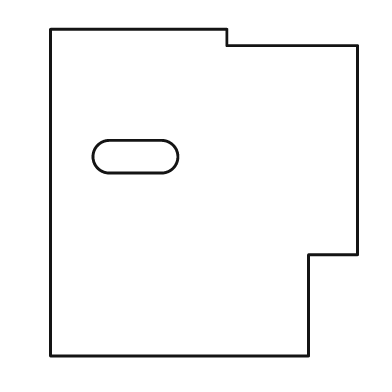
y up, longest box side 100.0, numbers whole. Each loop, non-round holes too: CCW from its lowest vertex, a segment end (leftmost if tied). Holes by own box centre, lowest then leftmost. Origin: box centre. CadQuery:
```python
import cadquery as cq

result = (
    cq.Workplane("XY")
    .moveTo(-47.0, -50.0)
    .lineTo(32.0, -50.0)
    .lineTo(32.0, -19.0)
    .lineTo(47.0, -19.0)
    .lineTo(47.0, 45.0)
    .lineTo(7.0, 45.0)
    .lineTo(7.0, 50.0)
    .lineTo(-47.0, 50.0)
    .close()
    .moveTo(-29.0, 6.0)
    .lineTo(-13.0, 6.0)
    .threePointArc((-8.0, 11.0), (-13.0, 16.0))
    .lineTo(-29.0, 16.0)
    .threePointArc((-34.0, 11.0), (-29.0, 6.0))
    .close()
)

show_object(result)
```